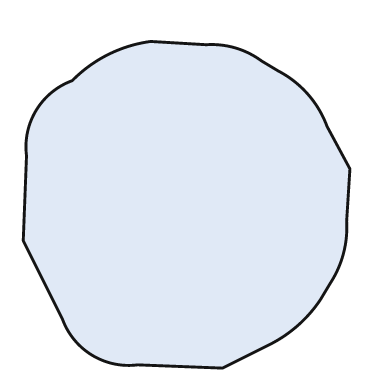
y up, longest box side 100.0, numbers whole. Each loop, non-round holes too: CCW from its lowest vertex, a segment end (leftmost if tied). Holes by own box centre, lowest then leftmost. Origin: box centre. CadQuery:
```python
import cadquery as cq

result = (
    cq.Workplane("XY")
    .moveTo(11.0, -50.0)
    .lineTo(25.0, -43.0)
    .threePointArc((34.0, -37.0), (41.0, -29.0))
    .lineTo(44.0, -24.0)
    .threePointArc((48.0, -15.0), (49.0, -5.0))
    .lineTo(50.0, 11.0)
    .lineTo(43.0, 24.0)
    .threePointArc((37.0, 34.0), (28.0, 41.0))
    .lineTo(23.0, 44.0)
    .threePointArc((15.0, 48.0), (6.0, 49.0))
    .lineTo(-11.0, 50.0)
    .threePointArc((-24.0, 46.0), (-35.0, 38.0))
    .threePointArc((-46.0, 29.0), (-49.0, 15.0))
    .lineTo(-50.0, -11.0)
    .lineTo(-38.0, -35.0)
    .threePointArc((-29.0, -46.0), (-15.0, -49.0))
    .close()
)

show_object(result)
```